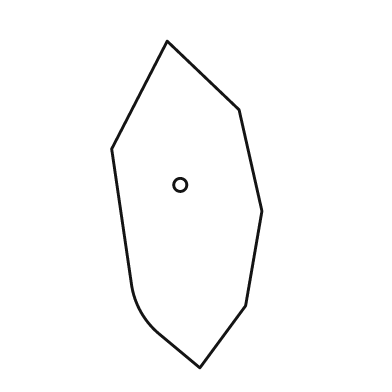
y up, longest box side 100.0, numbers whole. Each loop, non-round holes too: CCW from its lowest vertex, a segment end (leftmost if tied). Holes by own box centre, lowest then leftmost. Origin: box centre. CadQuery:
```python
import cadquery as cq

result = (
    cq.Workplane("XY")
    .moveTo(4.0, -50.0)
    .lineTo(18.0, -31.0)
    .lineTo(23.0, -2.0)
    .lineTo(16.0, 29.0)
    .lineTo(-6.0, 50.0)
    .lineTo(-23.0, 17.0)
    .lineTo(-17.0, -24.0)
    .threePointArc((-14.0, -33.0), (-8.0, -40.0))
    .close()
    .moveTo(-2.0, 6.0)
    .circle(2.0)
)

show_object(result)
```